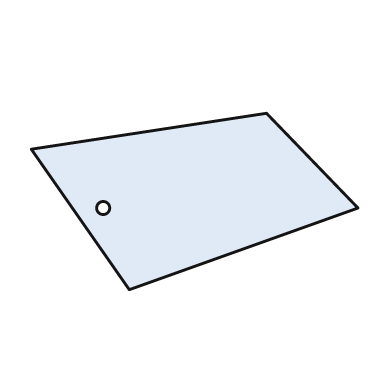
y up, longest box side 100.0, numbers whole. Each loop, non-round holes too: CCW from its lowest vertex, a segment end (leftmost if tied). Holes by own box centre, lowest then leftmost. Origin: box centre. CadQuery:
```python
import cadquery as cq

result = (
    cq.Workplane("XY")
    .moveTo(-20.0, -27.0)
    .lineTo(50.0, -2.0)
    .lineTo(22.0, 27.0)
    .lineTo(-50.0, 16.0)
    .close()
    .moveTo(-28.0, -2.0)
    .circle(2.0)
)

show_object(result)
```